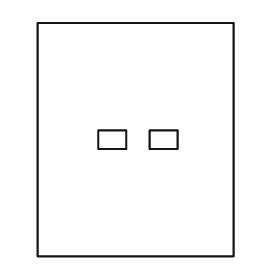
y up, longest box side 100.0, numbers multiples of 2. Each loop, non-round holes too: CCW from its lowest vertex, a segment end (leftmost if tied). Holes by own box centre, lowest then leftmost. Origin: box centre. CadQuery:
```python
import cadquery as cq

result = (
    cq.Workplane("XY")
    .moveTo(-42.0, -50.0)
    .lineTo(42.0, -50.0)
    .lineTo(42.0, 50.0)
    .lineTo(-42.0, 50.0)
    .close()
    .moveTo(-16.0, -4.0)
    .lineTo(-4.0, -4.0)
    .lineTo(-4.0, 4.0)
    .lineTo(-16.0, 4.0)
    .close()
    .moveTo(6.0, -4.0)
    .lineTo(18.0, -4.0)
    .lineTo(18.0, 4.0)
    .lineTo(6.0, 4.0)
    .close()
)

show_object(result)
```